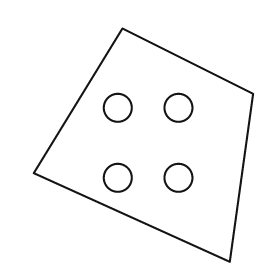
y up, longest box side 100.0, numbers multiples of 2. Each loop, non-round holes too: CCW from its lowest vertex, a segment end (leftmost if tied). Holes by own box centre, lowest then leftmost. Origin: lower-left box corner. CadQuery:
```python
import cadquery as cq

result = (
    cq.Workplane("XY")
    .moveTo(84.0, 0.0)
    .lineTo(94.0, 72.0)
    .lineTo(38.0, 100.0)
    .lineTo(0.0, 38.0)
    .close()
    .moveTo(36.0, 36.0)
    .circle(6.0)
    .moveTo(62.0, 36.0)
    .circle(6.0)
    .moveTo(36.0, 66.0)
    .circle(6.0)
    .moveTo(62.0, 66.0)
    .circle(6.0)
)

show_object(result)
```